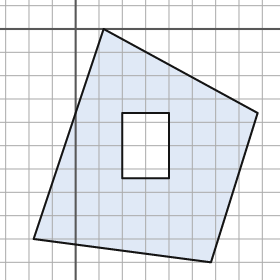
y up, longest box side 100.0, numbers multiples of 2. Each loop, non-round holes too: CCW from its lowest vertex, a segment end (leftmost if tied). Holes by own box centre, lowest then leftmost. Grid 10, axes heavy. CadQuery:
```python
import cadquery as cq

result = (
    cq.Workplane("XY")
    .moveTo(58.0, -100.0)
    .lineTo(78.0, -36.0)
    .lineTo(12.0, 0.0)
    .lineTo(-18.0, -90.0)
    .close()
    .moveTo(20.0, -64.0)
    .lineTo(40.0, -64.0)
    .lineTo(40.0, -36.0)
    .lineTo(20.0, -36.0)
    .close()
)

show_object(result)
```